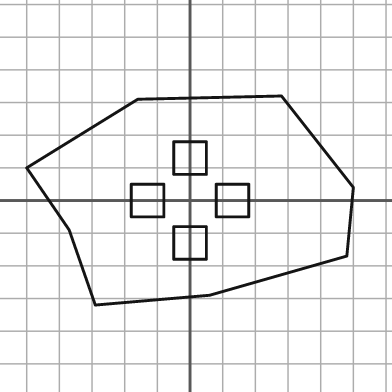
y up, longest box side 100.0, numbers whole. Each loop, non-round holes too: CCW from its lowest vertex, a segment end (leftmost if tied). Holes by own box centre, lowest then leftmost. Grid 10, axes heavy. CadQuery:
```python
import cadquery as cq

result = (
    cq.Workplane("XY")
    .moveTo(-29.0, -32.0)
    .lineTo(6.0, -29.0)
    .lineTo(48.0, -17.0)
    .lineTo(50.0, 4.0)
    .lineTo(28.0, 32.0)
    .lineTo(-16.0, 31.0)
    .lineTo(-50.0, 10.0)
    .lineTo(-37.0, -9.0)
    .close()
    .moveTo(-5.0, -18.0)
    .lineTo(5.0, -18.0)
    .lineTo(5.0, -8.0)
    .lineTo(-5.0, -8.0)
    .close()
    .moveTo(-18.0, -5.0)
    .lineTo(-8.0, -5.0)
    .lineTo(-8.0, 5.0)
    .lineTo(-18.0, 5.0)
    .close()
    .moveTo(8.0, -5.0)
    .lineTo(18.0, -5.0)
    .lineTo(18.0, 5.0)
    .lineTo(8.0, 5.0)
    .close()
    .moveTo(-5.0, 8.0)
    .lineTo(5.0, 8.0)
    .lineTo(5.0, 18.0)
    .lineTo(-5.0, 18.0)
    .close()
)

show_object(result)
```